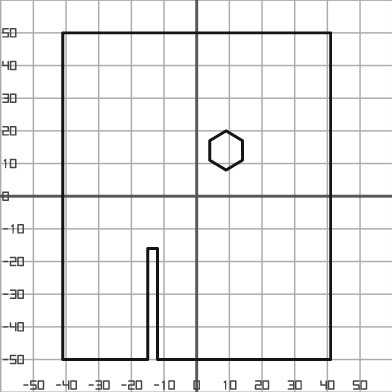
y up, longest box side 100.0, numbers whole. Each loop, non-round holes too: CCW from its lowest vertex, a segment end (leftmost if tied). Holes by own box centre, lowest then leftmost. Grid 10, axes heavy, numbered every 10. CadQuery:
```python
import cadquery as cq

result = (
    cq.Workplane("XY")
    .moveTo(-41.0, -50.0)
    .lineTo(-15.0, -50.0)
    .lineTo(-15.0, -16.0)
    .lineTo(-12.0, -16.0)
    .lineTo(-12.0, -50.0)
    .lineTo(41.0, -50.0)
    .lineTo(41.0, 50.0)
    .lineTo(-41.0, 50.0)
    .close()
    .moveTo(9.0, 8.0)
    .lineTo(14.0, 11.0)
    .lineTo(14.0, 17.0)
    .lineTo(9.0, 20.0)
    .lineTo(4.0, 17.0)
    .lineTo(4.0, 11.0)
    .close()
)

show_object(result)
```